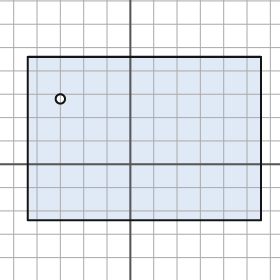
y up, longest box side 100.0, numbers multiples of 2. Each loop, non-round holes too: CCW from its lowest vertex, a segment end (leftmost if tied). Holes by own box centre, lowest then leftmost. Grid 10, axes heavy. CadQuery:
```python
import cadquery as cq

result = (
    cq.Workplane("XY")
    .moveTo(-44.0, -24.0)
    .lineTo(56.0, -24.0)
    .lineTo(56.0, 46.0)
    .lineTo(-44.0, 46.0)
    .close()
    .moveTo(-30.0, 28.0)
    .circle(2.0)
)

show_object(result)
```